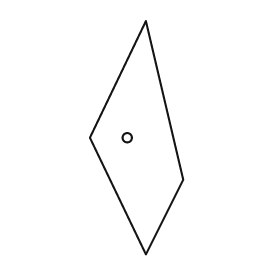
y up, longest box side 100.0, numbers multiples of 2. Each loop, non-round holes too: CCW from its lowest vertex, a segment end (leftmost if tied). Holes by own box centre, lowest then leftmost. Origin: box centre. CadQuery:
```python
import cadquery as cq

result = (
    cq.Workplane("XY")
    .moveTo(4.0, -50.0)
    .lineTo(20.0, -18.0)
    .lineTo(4.0, 50.0)
    .lineTo(-20.0, 0.0)
    .close()
    .moveTo(-4.0, 0.0)
    .circle(2.0)
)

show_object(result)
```